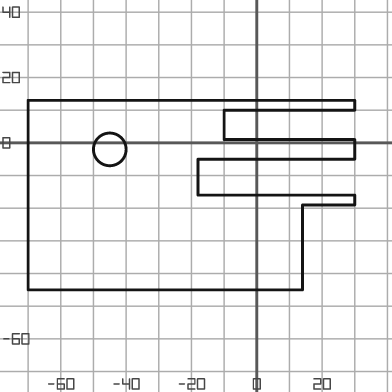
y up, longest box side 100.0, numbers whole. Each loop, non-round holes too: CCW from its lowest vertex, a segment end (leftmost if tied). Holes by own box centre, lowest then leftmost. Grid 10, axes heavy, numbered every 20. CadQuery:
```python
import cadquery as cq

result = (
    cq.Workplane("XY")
    .moveTo(-70.0, -45.0)
    .lineTo(14.0, -45.0)
    .lineTo(14.0, -19.0)
    .lineTo(30.0, -19.0)
    .lineTo(30.0, -16.0)
    .lineTo(-18.0, -16.0)
    .lineTo(-18.0, -5.0)
    .lineTo(30.0, -5.0)
    .lineTo(30.0, 1.0)
    .lineTo(-10.0, 1.0)
    .lineTo(-10.0, 10.0)
    .lineTo(30.0, 10.0)
    .lineTo(30.0, 13.0)
    .lineTo(-70.0, 13.0)
    .close()
    .moveTo(-45.0, -2.0)
    .circle(5.0)
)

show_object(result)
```